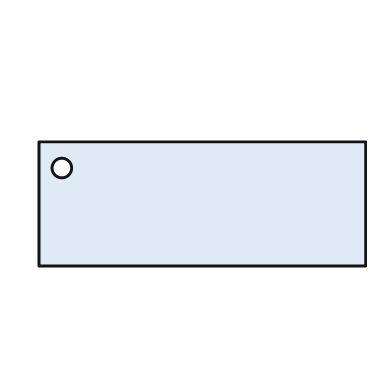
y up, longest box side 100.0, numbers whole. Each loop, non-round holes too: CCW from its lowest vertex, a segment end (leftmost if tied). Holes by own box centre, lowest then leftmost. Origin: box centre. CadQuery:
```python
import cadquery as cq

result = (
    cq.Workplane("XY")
    .moveTo(-50.0, -19.0)
    .lineTo(50.0, -19.0)
    .lineTo(50.0, 19.0)
    .lineTo(-50.0, 19.0)
    .close()
    .moveTo(-43.0, 11.0)
    .circle(3.0)
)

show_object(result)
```